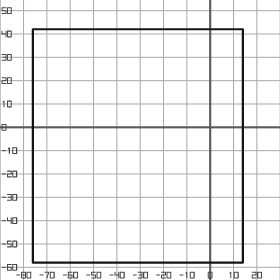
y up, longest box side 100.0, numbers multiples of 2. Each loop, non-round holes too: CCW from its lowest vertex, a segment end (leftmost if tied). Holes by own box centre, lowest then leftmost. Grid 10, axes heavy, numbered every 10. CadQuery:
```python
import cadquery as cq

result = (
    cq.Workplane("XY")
    .moveTo(-76.0, -58.0)
    .lineTo(14.0, -58.0)
    .lineTo(14.0, 42.0)
    .lineTo(-76.0, 42.0)
    .close()
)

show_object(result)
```